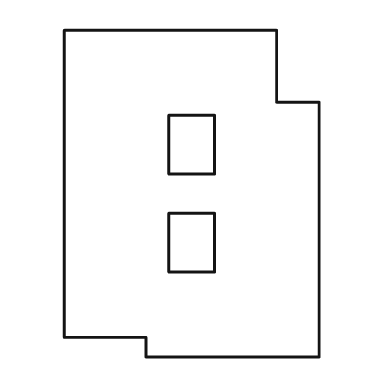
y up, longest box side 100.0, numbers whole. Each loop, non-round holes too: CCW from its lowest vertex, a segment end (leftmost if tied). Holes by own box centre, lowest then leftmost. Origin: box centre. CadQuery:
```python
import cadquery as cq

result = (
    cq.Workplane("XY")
    .moveTo(-14.0, -50.0)
    .lineTo(39.0, -50.0)
    .lineTo(39.0, 28.0)
    .lineTo(26.0, 28.0)
    .lineTo(26.0, 50.0)
    .lineTo(-39.0, 50.0)
    .lineTo(-39.0, -44.0)
    .lineTo(-14.0, -44.0)
    .close()
    .moveTo(-7.0, -24.0)
    .lineTo(7.0, -24.0)
    .lineTo(7.0, -6.0)
    .lineTo(-7.0, -6.0)
    .close()
    .moveTo(-7.0, 6.0)
    .lineTo(7.0, 6.0)
    .lineTo(7.0, 24.0)
    .lineTo(-7.0, 24.0)
    .close()
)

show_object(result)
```